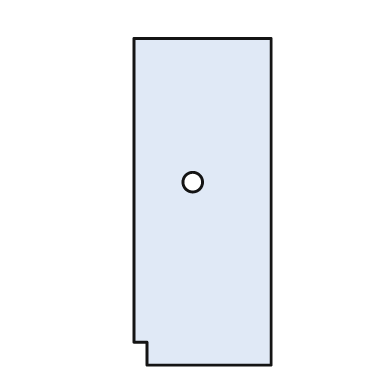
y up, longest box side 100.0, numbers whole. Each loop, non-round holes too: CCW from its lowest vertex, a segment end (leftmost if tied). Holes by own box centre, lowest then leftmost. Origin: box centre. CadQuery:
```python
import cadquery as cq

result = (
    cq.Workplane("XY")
    .moveTo(-17.0, -50.0)
    .lineTo(21.0, -50.0)
    .lineTo(21.0, 50.0)
    .lineTo(-21.0, 50.0)
    .lineTo(-21.0, -43.0)
    .lineTo(-17.0, -43.0)
    .close()
    .moveTo(-3.0, 6.0)
    .circle(3.0)
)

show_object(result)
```